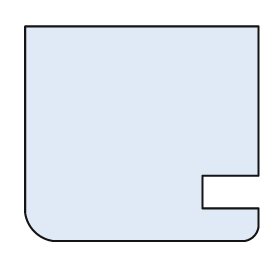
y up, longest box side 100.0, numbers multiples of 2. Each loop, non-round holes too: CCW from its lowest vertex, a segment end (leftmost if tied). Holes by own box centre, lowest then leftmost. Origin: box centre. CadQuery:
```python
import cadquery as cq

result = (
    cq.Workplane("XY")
    .moveTo(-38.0, -46.0)
    .lineTo(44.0, -46.0)
    .threePointArc((48.0, -44.0), (50.0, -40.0))
    .lineTo(50.0, -32.0)
    .lineTo(26.0, -32.0)
    .lineTo(26.0, -18.0)
    .lineTo(50.0, -18.0)
    .lineTo(50.0, 46.0)
    .lineTo(-50.0, 46.0)
    .lineTo(-50.0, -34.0)
    .threePointArc((-46.0, -42.0), (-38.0, -46.0))
    .close()
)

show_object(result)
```